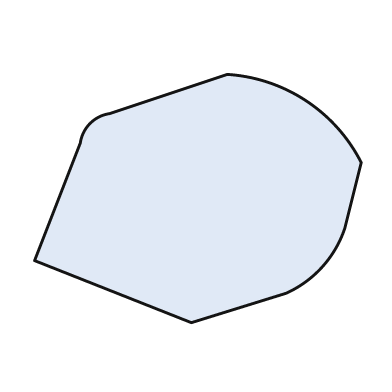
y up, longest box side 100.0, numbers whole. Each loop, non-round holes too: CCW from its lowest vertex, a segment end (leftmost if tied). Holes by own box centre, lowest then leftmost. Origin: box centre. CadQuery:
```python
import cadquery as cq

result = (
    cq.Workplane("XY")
    .moveTo(-2.0, -38.0)
    .lineTo(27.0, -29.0)
    .threePointArc((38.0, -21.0), (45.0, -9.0))
    .lineTo(50.0, 11.0)
    .threePointArc((33.0, 30.0), (9.0, 38.0))
    .lineTo(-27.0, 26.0)
    .threePointArc((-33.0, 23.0), (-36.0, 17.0))
    .lineTo(-50.0, -19.0)
    .close()
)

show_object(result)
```